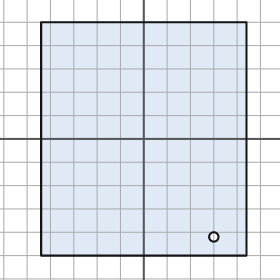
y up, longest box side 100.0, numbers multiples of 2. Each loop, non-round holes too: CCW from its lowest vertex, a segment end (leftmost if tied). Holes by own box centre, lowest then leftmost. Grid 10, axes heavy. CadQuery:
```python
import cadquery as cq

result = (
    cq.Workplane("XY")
    .moveTo(-44.0, -50.0)
    .lineTo(44.0, -50.0)
    .lineTo(44.0, 50.0)
    .lineTo(-44.0, 50.0)
    .close()
    .moveTo(30.0, -42.0)
    .circle(2.0)
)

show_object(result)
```